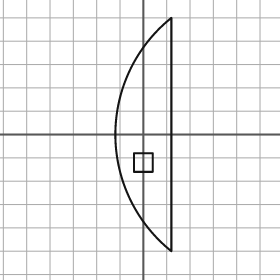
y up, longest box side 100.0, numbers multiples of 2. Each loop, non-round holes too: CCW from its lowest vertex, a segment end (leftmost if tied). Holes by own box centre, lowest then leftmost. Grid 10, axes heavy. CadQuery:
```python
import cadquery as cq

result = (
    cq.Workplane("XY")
    .moveTo(12.0, -50.0)
    .lineTo(12.0, 50.0)
    .threePointArc((-12.0, 0.0), (12.0, -50.0))
    .close()
    .moveTo(-4.0, -16.0)
    .lineTo(4.0, -16.0)
    .lineTo(4.0, -8.0)
    .lineTo(-4.0, -8.0)
    .close()
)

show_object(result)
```